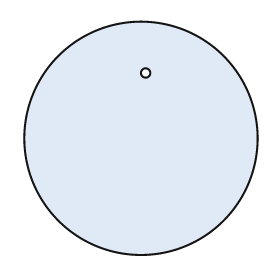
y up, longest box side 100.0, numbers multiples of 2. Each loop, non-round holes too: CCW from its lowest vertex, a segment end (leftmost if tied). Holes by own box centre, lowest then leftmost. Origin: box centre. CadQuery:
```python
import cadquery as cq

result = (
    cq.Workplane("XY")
    .moveTo(0.0, 0.0)
    .circle(50.0)
    .moveTo(2.0, 28.0)
    .circle(2.0)
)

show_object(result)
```